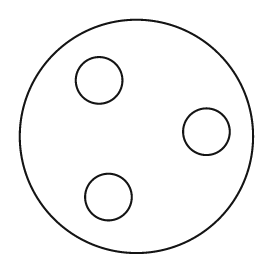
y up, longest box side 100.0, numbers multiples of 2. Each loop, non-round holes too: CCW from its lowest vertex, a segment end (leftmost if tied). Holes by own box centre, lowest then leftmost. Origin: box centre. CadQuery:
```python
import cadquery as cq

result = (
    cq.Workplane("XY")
    .moveTo(0.0, 0.0)
    .circle(50.0)
    .moveTo(-12.0, -26.0)
    .circle(10.0)
    .moveTo(30.0, 2.0)
    .circle(10.0)
    .moveTo(-16.0, 24.0)
    .circle(10.0)
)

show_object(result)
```